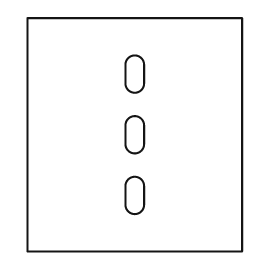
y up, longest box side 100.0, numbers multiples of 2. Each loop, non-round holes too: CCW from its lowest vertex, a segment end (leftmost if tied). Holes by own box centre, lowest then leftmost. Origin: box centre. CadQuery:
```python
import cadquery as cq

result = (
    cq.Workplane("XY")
    .moveTo(-46.0, -50.0)
    .lineTo(46.0, -50.0)
    .lineTo(46.0, 50.0)
    .lineTo(-46.0, 50.0)
    .close()
    .moveTo(-4.0, -30.0)
    .threePointArc((0.0, -34.0), (4.0, -30.0))
    .lineTo(4.0, -22.0)
    .threePointArc((0.0, -18.0), (-4.0, -22.0))
    .close()
    .moveTo(-4.0, -4.0)
    .threePointArc((0.0, -8.0), (4.0, -4.0))
    .lineTo(4.0, 4.0)
    .threePointArc((0.0, 8.0), (-4.0, 4.0))
    .close()
    .moveTo(-4.0, 22.0)
    .threePointArc((0.0, 18.0), (4.0, 22.0))
    .lineTo(4.0, 30.0)
    .threePointArc((0.0, 34.0), (-4.0, 30.0))
    .close()
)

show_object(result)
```